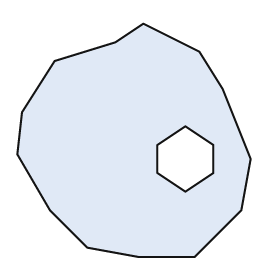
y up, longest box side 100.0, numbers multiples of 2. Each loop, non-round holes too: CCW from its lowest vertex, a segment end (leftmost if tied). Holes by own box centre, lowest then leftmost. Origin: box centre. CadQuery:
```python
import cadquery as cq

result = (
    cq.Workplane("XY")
    .moveTo(2.0, -50.0)
    .lineTo(26.0, -50.0)
    .lineTo(46.0, -30.0)
    .lineTo(50.0, -8.0)
    .lineTo(38.0, 22.0)
    .lineTo(28.0, 38.0)
    .lineTo(4.0, 50.0)
    .lineTo(-8.0, 42.0)
    .lineTo(-34.0, 34.0)
    .lineTo(-48.0, 12.0)
    .lineTo(-50.0, -6.0)
    .lineTo(-36.0, -30.0)
    .lineTo(-20.0, -46.0)
    .close()
    .moveTo(22.0, -22.0)
    .lineTo(34.0, -14.0)
    .lineTo(34.0, -2.0)
    .lineTo(22.0, 6.0)
    .lineTo(10.0, -2.0)
    .lineTo(10.0, -14.0)
    .close()
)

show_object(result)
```